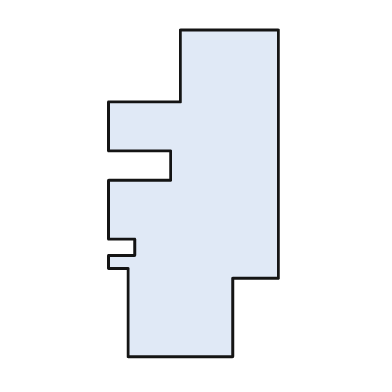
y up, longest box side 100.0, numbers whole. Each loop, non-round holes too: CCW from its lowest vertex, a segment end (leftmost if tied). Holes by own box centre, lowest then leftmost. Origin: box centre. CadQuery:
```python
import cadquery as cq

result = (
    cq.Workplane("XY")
    .moveTo(-20.0, -50.0)
    .lineTo(12.0, -50.0)
    .lineTo(12.0, -26.0)
    .lineTo(26.0, -26.0)
    .lineTo(26.0, 50.0)
    .lineTo(-4.0, 50.0)
    .lineTo(-4.0, 28.0)
    .lineTo(-26.0, 28.0)
    .lineTo(-26.0, 13.0)
    .lineTo(-7.0, 13.0)
    .lineTo(-7.0, 4.0)
    .lineTo(-26.0, 4.0)
    .lineTo(-26.0, -14.0)
    .lineTo(-18.0, -14.0)
    .lineTo(-18.0, -19.0)
    .lineTo(-26.0, -19.0)
    .lineTo(-26.0, -23.0)
    .lineTo(-20.0, -23.0)
    .close()
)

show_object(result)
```